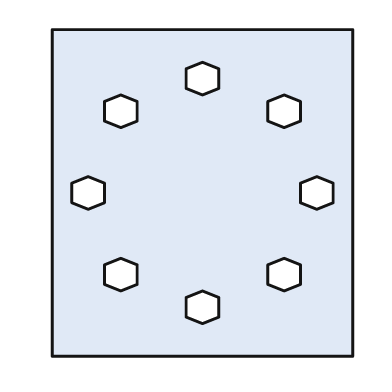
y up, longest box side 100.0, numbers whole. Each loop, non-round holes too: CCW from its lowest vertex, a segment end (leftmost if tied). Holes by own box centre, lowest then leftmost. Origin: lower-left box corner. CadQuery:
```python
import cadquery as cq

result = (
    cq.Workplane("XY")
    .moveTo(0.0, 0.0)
    .lineTo(92.0, 0.0)
    .lineTo(92.0, 100.0)
    .lineTo(0.0, 100.0)
    .close()
    .moveTo(46.0, 10.0)
    .lineTo(51.0, 12.0)
    .lineTo(51.0, 18.0)
    .lineTo(46.0, 20.0)
    .lineTo(41.0, 18.0)
    .lineTo(41.0, 12.0)
    .close()
    .moveTo(21.0, 20.0)
    .lineTo(26.0, 22.0)
    .lineTo(26.0, 28.0)
    .lineTo(21.0, 30.0)
    .lineTo(16.0, 28.0)
    .lineTo(16.0, 22.0)
    .close()
    .moveTo(71.0, 20.0)
    .lineTo(76.0, 22.0)
    .lineTo(76.0, 28.0)
    .lineTo(71.0, 30.0)
    .lineTo(66.0, 28.0)
    .lineTo(66.0, 22.0)
    .close()
    .moveTo(11.0, 45.0)
    .lineTo(16.0, 47.0)
    .lineTo(16.0, 53.0)
    .lineTo(11.0, 55.0)
    .lineTo(6.0, 53.0)
    .lineTo(6.0, 47.0)
    .close()
    .moveTo(81.0, 45.0)
    .lineTo(86.0, 47.0)
    .lineTo(86.0, 53.0)
    .lineTo(81.0, 55.0)
    .lineTo(76.0, 53.0)
    .lineTo(76.0, 47.0)
    .close()
    .moveTo(21.0, 70.0)
    .lineTo(26.0, 72.0)
    .lineTo(26.0, 78.0)
    .lineTo(21.0, 80.0)
    .lineTo(16.0, 78.0)
    .lineTo(16.0, 72.0)
    .close()
    .moveTo(71.0, 70.0)
    .lineTo(76.0, 72.0)
    .lineTo(76.0, 78.0)
    .lineTo(71.0, 80.0)
    .lineTo(66.0, 78.0)
    .lineTo(66.0, 72.0)
    .close()
    .moveTo(46.0, 80.0)
    .lineTo(51.0, 82.0)
    .lineTo(51.0, 88.0)
    .lineTo(46.0, 90.0)
    .lineTo(41.0, 88.0)
    .lineTo(41.0, 82.0)
    .close()
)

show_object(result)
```